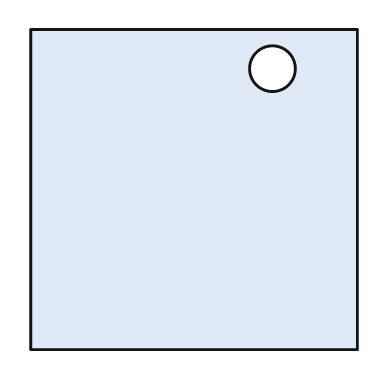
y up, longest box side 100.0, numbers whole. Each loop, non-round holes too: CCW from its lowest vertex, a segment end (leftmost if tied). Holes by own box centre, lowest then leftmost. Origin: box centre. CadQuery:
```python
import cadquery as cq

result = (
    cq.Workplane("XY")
    .moveTo(-50.0, -49.0)
    .lineTo(50.0, -49.0)
    .lineTo(50.0, 49.0)
    .lineTo(-50.0, 49.0)
    .close()
    .moveTo(24.0, 37.0)
    .circle(7.0)
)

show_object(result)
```